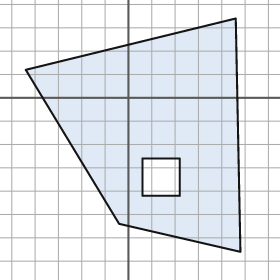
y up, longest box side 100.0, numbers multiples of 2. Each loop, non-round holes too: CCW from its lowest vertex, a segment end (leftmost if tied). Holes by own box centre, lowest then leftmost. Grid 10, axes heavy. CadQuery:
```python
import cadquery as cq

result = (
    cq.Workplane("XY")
    .moveTo(48.0, -66.0)
    .lineTo(46.0, 34.0)
    .lineTo(-44.0, 12.0)
    .lineTo(-4.0, -54.0)
    .close()
    .moveTo(6.0, -42.0)
    .lineTo(22.0, -42.0)
    .lineTo(22.0, -26.0)
    .lineTo(6.0, -26.0)
    .close()
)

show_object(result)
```